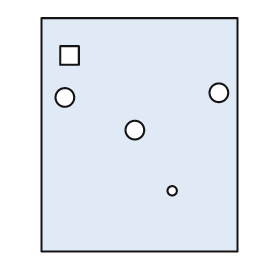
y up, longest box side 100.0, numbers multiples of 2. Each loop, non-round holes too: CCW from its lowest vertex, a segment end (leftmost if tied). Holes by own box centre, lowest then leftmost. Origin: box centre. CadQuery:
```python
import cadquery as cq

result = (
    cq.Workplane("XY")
    .moveTo(-42.0, -50.0)
    .lineTo(42.0, -50.0)
    .lineTo(42.0, 50.0)
    .lineTo(-42.0, 50.0)
    .close()
    .moveTo(14.0, -24.0)
    .circle(2.0)
    .moveTo(-2.0, 2.0)
    .circle(4.0)
    .moveTo(-32.0, 16.0)
    .circle(4.0)
    .moveTo(34.0, 18.0)
    .circle(4.0)
    .moveTo(-34.0, 30.0)
    .lineTo(-26.0, 30.0)
    .lineTo(-26.0, 38.0)
    .lineTo(-34.0, 38.0)
    .close()
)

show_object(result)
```